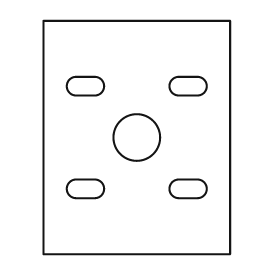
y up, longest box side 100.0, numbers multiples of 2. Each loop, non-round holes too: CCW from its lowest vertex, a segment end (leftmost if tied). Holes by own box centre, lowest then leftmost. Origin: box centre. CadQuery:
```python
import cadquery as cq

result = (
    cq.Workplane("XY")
    .moveTo(-40.0, -50.0)
    .lineTo(40.0, -50.0)
    .lineTo(40.0, 50.0)
    .lineTo(-40.0, 50.0)
    .close()
    .moveTo(-26.0, -26.0)
    .lineTo(-18.0, -26.0)
    .threePointArc((-14.0, -22.0), (-18.0, -18.0))
    .lineTo(-26.0, -18.0)
    .threePointArc((-30.0, -22.0), (-26.0, -26.0))
    .close()
    .moveTo(18.0, -26.0)
    .lineTo(26.0, -26.0)
    .threePointArc((30.0, -22.0), (26.0, -18.0))
    .lineTo(18.0, -18.0)
    .threePointArc((14.0, -22.0), (18.0, -26.0))
    .close()
    .moveTo(0.0, 0.0)
    .circle(10.0)
    .moveTo(-26.0, 18.0)
    .lineTo(-18.0, 18.0)
    .threePointArc((-14.0, 22.0), (-18.0, 26.0))
    .lineTo(-26.0, 26.0)
    .threePointArc((-30.0, 22.0), (-26.0, 18.0))
    .close()
    .moveTo(18.0, 18.0)
    .lineTo(26.0, 18.0)
    .threePointArc((30.0, 22.0), (26.0, 26.0))
    .lineTo(18.0, 26.0)
    .threePointArc((14.0, 22.0), (18.0, 18.0))
    .close()
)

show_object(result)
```